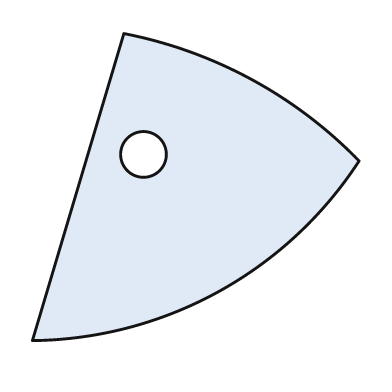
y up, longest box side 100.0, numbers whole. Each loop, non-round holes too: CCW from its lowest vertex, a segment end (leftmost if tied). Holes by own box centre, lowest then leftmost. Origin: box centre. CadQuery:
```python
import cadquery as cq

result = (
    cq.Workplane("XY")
    .moveTo(-50.0, -47.0)
    .threePointArc((7.0, -32.0), (50.0, 8.0))
    .threePointArc((17.0, 33.0), (-22.0, 47.0))
    .close()
    .moveTo(-16.0, 10.0)
    .circle(7.0)
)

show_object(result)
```